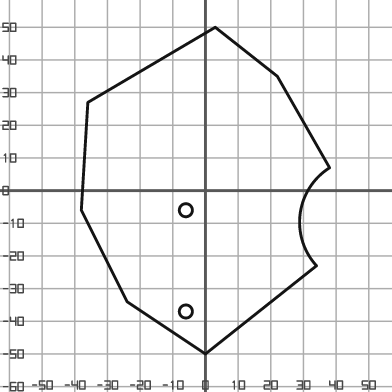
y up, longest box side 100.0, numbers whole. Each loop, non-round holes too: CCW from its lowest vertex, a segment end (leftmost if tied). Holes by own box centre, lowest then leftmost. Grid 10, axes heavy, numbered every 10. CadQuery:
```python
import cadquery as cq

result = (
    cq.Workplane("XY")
    .moveTo(0.0, -50.0)
    .lineTo(34.0, -23.0)
    .threePointArc((29.0, -7.0), (38.0, 7.0))
    .lineTo(22.0, 35.0)
    .lineTo(3.0, 50.0)
    .lineTo(-36.0, 27.0)
    .lineTo(-38.0, -6.0)
    .lineTo(-24.0, -34.0)
    .close()
    .moveTo(-6.0, -37.0)
    .circle(2.0)
    .moveTo(-6.0, -6.0)
    .circle(2.0)
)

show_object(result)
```